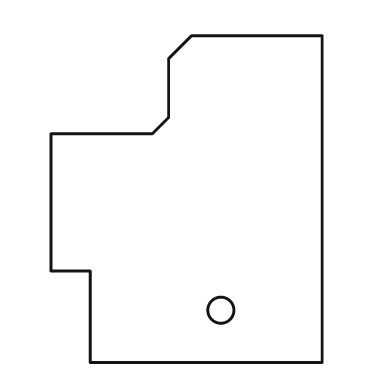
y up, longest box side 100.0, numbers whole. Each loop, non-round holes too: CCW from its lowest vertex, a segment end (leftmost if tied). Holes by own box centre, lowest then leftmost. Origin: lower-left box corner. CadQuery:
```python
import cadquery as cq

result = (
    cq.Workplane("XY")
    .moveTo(12.0, 0.0)
    .lineTo(83.0, 0.0)
    .lineTo(83.0, 100.0)
    .lineTo(43.0, 100.0)
    .lineTo(36.0, 93.0)
    .lineTo(36.0, 75.0)
    .lineTo(31.0, 70.0)
    .lineTo(0.0, 70.0)
    .lineTo(0.0, 28.0)
    .lineTo(12.0, 28.0)
    .close()
    .moveTo(52.0, 16.0)
    .circle(4.0)
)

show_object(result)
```